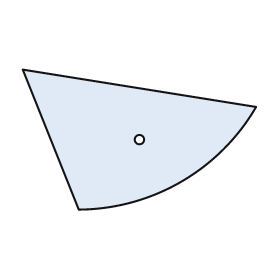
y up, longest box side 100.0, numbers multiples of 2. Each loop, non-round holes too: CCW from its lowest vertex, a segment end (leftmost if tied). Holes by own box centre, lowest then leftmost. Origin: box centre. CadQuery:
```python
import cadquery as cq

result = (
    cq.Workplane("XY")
    .moveTo(-26.0, -30.0)
    .threePointArc((18.0, -18.0), (50.0, 14.0))
    .lineTo(-50.0, 30.0)
    .close()
    .moveTo(0.0, 0.0)
    .circle(2.0)
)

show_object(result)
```